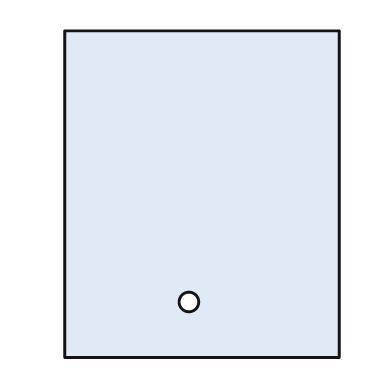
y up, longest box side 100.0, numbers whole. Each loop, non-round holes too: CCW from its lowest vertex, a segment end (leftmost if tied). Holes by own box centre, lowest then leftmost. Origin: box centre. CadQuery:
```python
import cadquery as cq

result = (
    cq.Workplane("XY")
    .moveTo(-42.0, -50.0)
    .lineTo(42.0, -50.0)
    .lineTo(42.0, 50.0)
    .lineTo(-42.0, 50.0)
    .close()
    .moveTo(-4.0, -33.0)
    .circle(3.0)
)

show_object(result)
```